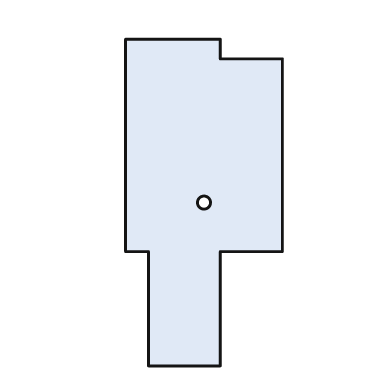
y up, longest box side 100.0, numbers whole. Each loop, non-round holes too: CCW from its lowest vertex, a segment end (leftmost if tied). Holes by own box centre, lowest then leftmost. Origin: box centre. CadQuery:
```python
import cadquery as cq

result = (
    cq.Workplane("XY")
    .moveTo(-17.0, -50.0)
    .lineTo(5.0, -50.0)
    .lineTo(5.0, -15.0)
    .lineTo(24.0, -15.0)
    .lineTo(24.0, 44.0)
    .lineTo(5.0, 44.0)
    .lineTo(5.0, 50.0)
    .lineTo(-24.0, 50.0)
    .lineTo(-24.0, -15.0)
    .lineTo(-17.0, -15.0)
    .close()
    .moveTo(0.0, 0.0)
    .circle(2.0)
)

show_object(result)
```